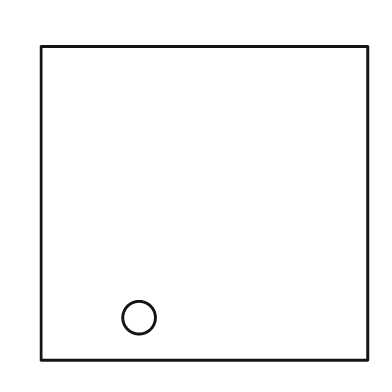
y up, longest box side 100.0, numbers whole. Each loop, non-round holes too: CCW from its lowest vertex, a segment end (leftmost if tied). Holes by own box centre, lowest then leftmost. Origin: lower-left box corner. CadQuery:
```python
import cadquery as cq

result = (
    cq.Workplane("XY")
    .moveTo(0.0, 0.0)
    .lineTo(100.0, 0.0)
    .lineTo(100.0, 96.0)
    .lineTo(0.0, 96.0)
    .close()
    .moveTo(30.0, 13.0)
    .circle(5.0)
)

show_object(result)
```